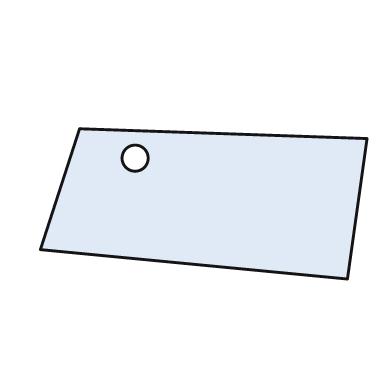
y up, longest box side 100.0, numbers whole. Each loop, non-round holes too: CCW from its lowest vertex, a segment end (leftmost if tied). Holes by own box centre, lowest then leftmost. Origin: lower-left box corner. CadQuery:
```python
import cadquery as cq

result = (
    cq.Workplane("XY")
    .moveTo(94.0, 0.0)
    .lineTo(100.0, 43.0)
    .lineTo(12.0, 46.0)
    .lineTo(0.0, 9.0)
    .close()
    .moveTo(29.0, 37.0)
    .circle(4.0)
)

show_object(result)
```